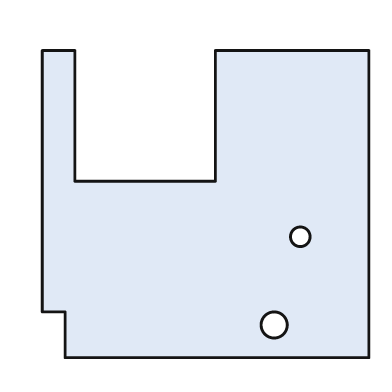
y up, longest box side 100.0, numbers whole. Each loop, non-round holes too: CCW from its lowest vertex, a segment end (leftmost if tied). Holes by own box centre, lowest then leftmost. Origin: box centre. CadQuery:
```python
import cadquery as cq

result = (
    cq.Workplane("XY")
    .moveTo(-43.0, -47.0)
    .lineTo(50.0, -47.0)
    .lineTo(50.0, 47.0)
    .lineTo(3.0, 47.0)
    .lineTo(3.0, 7.0)
    .lineTo(-40.0, 7.0)
    .lineTo(-40.0, 47.0)
    .lineTo(-50.0, 47.0)
    .lineTo(-50.0, -33.0)
    .lineTo(-43.0, -33.0)
    .close()
    .moveTo(21.0, -37.0)
    .circle(4.0)
    .moveTo(29.0, -10.0)
    .circle(3.0)
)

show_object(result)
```